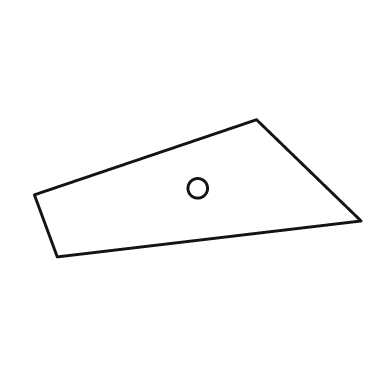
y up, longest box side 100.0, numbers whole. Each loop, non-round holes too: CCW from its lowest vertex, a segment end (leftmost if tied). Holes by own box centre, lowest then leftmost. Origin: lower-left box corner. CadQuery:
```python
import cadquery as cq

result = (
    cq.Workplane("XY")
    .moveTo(7.0, 0.0)
    .lineTo(100.0, 11.0)
    .lineTo(68.0, 42.0)
    .lineTo(0.0, 19.0)
    .close()
    .moveTo(50.0, 21.0)
    .circle(3.0)
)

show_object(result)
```